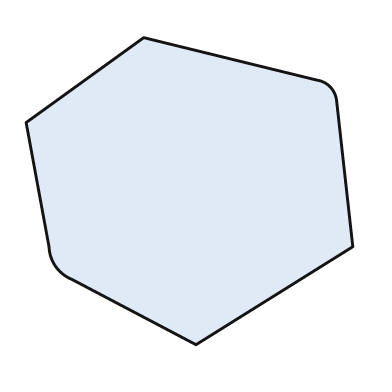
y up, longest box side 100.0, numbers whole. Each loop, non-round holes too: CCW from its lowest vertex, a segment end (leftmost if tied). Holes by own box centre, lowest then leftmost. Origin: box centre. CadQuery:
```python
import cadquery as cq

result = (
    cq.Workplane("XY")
    .moveTo(2.0, -47.0)
    .lineTo(50.0, -17.0)
    .lineTo(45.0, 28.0)
    .threePointArc((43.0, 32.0), (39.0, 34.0))
    .lineTo(-14.0, 47.0)
    .lineTo(-50.0, 21.0)
    .lineTo(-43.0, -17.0)
    .threePointArc((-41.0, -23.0), (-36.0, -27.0))
    .close()
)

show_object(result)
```